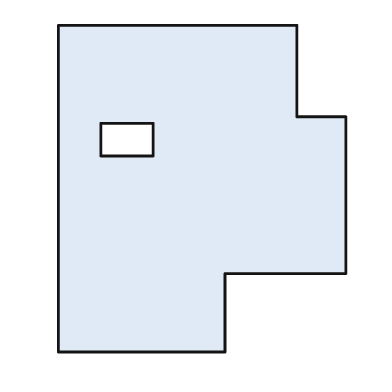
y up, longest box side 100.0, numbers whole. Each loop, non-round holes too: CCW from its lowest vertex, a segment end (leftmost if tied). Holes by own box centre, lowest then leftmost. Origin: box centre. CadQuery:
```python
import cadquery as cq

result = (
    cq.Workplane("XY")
    .moveTo(-44.0, -50.0)
    .lineTo(7.0, -50.0)
    .lineTo(7.0, -26.0)
    .lineTo(44.0, -26.0)
    .lineTo(44.0, 22.0)
    .lineTo(29.0, 22.0)
    .lineTo(29.0, 50.0)
    .lineTo(-44.0, 50.0)
    .close()
    .moveTo(-31.0, 10.0)
    .lineTo(-15.0, 10.0)
    .lineTo(-15.0, 20.0)
    .lineTo(-31.0, 20.0)
    .close()
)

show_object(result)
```